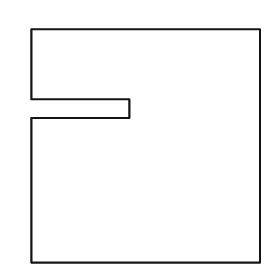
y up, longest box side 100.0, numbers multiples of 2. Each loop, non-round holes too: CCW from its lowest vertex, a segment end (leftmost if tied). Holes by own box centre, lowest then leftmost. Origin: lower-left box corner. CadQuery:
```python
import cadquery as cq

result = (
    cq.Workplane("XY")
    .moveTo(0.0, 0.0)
    .lineTo(98.0, 0.0)
    .lineTo(98.0, 100.0)
    .lineTo(0.0, 100.0)
    .lineTo(0.0, 70.0)
    .lineTo(42.0, 70.0)
    .lineTo(42.0, 62.0)
    .lineTo(0.0, 62.0)
    .close()
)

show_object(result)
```